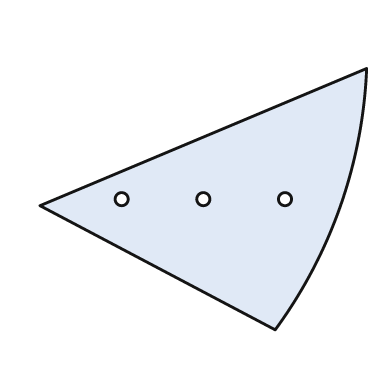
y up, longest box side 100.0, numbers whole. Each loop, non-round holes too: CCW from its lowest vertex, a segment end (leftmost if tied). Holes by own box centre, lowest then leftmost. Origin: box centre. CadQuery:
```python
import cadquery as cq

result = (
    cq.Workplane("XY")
    .moveTo(22.0, -40.0)
    .threePointArc((42.0, -2.0), (50.0, 40.0))
    .lineTo(-50.0, -2.0)
    .close()
    .moveTo(-25.0, 0.0)
    .circle(2.0)
    .moveTo(0.0, 0.0)
    .circle(2.0)
    .moveTo(25.0, 0.0)
    .circle(2.0)
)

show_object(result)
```